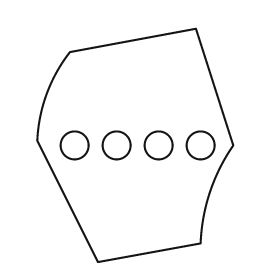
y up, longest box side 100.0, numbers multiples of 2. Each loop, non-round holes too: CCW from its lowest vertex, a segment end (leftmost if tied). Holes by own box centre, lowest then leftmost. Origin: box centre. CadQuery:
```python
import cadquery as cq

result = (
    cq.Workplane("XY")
    .moveTo(-16.0, -50.0)
    .lineTo(28.0, -42.0)
    .threePointArc((32.0, -20.0), (42.0, 0.0))
    .lineTo(26.0, 50.0)
    .lineTo(-28.0, 40.0)
    .threePointArc((-38.0, 22.0), (-42.0, 2.0))
    .close()
    .moveTo(-26.0, 0.0)
    .circle(6.0)
    .moveTo(-8.0, 0.0)
    .circle(6.0)
    .moveTo(10.0, 0.0)
    .circle(6.0)
    .moveTo(28.0, 0.0)
    .circle(6.0)
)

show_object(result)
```